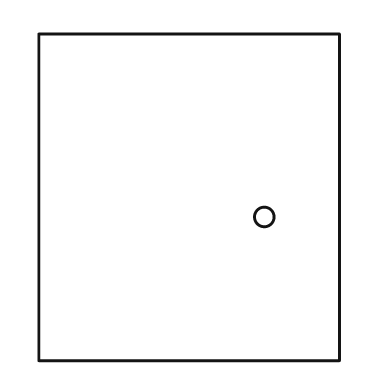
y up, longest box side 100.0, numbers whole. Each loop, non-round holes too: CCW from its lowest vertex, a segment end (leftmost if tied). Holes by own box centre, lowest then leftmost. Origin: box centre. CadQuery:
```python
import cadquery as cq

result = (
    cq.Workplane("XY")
    .moveTo(-46.0, -50.0)
    .lineTo(46.0, -50.0)
    .lineTo(46.0, 50.0)
    .lineTo(-46.0, 50.0)
    .close()
    .moveTo(23.0, -6.0)
    .circle(3.0)
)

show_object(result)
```